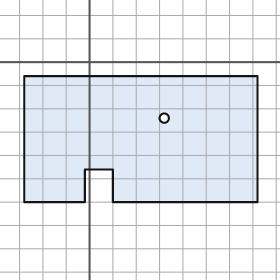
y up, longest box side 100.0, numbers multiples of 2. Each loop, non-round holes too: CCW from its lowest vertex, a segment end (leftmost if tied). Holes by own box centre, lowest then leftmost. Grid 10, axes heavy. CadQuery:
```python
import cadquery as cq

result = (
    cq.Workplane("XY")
    .moveTo(-28.0, -60.0)
    .lineTo(-2.0, -60.0)
    .lineTo(-2.0, -46.0)
    .lineTo(10.0, -46.0)
    .lineTo(10.0, -60.0)
    .lineTo(72.0, -60.0)
    .lineTo(72.0, -6.0)
    .lineTo(-28.0, -6.0)
    .close()
    .moveTo(32.0, -24.0)
    .circle(2.0)
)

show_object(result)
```